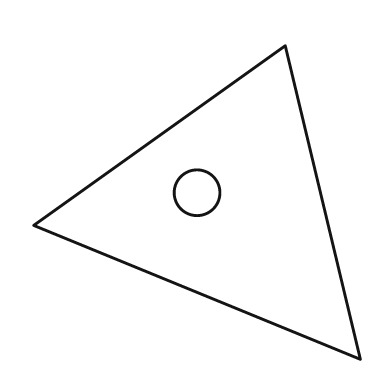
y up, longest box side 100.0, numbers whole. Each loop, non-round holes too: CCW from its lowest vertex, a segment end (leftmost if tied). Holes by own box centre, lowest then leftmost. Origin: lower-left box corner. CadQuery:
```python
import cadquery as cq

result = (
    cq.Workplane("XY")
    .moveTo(100.0, 0.0)
    .lineTo(77.0, 96.0)
    .lineTo(0.0, 41.0)
    .close()
    .moveTo(50.0, 51.0)
    .circle(7.0)
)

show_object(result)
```